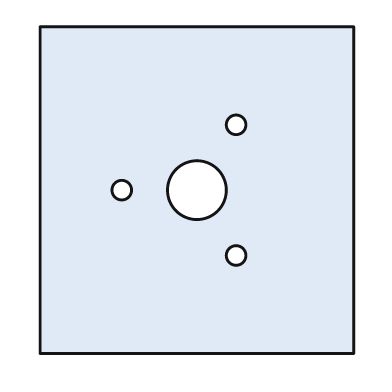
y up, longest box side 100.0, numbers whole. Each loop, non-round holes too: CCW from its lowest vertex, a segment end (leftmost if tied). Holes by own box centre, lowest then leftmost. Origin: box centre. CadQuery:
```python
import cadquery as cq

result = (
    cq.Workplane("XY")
    .moveTo(-48.0, -50.0)
    .lineTo(48.0, -50.0)
    .lineTo(48.0, 50.0)
    .lineTo(-48.0, 50.0)
    .close()
    .moveTo(12.0, -20.0)
    .circle(3.0)
    .moveTo(-23.0, 0.0)
    .circle(3.0)
    .moveTo(0.0, 0.0)
    .circle(9.0)
    .moveTo(12.0, 20.0)
    .circle(3.0)
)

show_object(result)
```